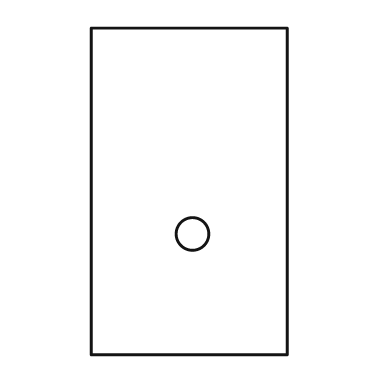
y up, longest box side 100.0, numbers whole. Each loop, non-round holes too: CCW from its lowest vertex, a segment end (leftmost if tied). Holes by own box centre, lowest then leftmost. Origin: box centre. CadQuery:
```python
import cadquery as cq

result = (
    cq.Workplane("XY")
    .moveTo(-30.0, -50.0)
    .lineTo(30.0, -50.0)
    .lineTo(30.0, 50.0)
    .lineTo(-30.0, 50.0)
    .close()
    .moveTo(1.0, -13.0)
    .circle(5.0)
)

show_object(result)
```